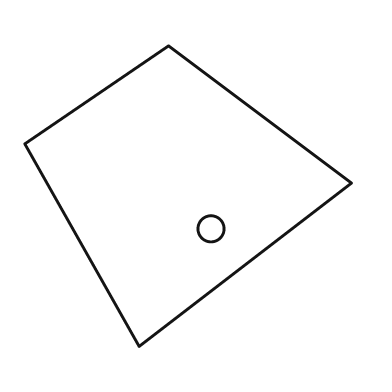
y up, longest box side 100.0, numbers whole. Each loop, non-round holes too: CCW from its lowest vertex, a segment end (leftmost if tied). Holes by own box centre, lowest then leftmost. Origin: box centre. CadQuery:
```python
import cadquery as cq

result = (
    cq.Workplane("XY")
    .moveTo(-15.0, -46.0)
    .lineTo(50.0, 4.0)
    .lineTo(-6.0, 46.0)
    .lineTo(-50.0, 16.0)
    .close()
    .moveTo(7.0, -10.0)
    .circle(4.0)
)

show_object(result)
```